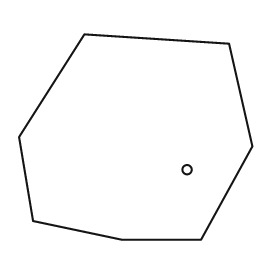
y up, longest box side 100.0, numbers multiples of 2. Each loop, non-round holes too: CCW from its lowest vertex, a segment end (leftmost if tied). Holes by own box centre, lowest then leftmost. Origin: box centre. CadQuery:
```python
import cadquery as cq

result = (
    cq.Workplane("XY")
    .moveTo(-6.0, -44.0)
    .lineTo(28.0, -44.0)
    .lineTo(50.0, -4.0)
    .lineTo(40.0, 40.0)
    .lineTo(-22.0, 44.0)
    .lineTo(-50.0, 0.0)
    .lineTo(-44.0, -36.0)
    .close()
    .moveTo(22.0, -14.0)
    .circle(2.0)
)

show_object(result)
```